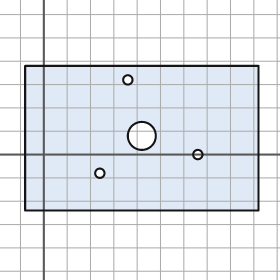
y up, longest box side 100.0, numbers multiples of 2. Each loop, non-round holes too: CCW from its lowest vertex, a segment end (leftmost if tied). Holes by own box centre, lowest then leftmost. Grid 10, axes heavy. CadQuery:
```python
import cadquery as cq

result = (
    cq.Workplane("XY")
    .moveTo(-8.0, -24.0)
    .lineTo(92.0, -24.0)
    .lineTo(92.0, 38.0)
    .lineTo(-8.0, 38.0)
    .close()
    .moveTo(24.0, -8.0)
    .circle(2.0)
    .moveTo(66.0, 0.0)
    .circle(2.0)
    .moveTo(42.0, 8.0)
    .circle(6.0)
    .moveTo(36.0, 32.0)
    .circle(2.0)
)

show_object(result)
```